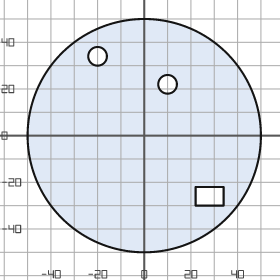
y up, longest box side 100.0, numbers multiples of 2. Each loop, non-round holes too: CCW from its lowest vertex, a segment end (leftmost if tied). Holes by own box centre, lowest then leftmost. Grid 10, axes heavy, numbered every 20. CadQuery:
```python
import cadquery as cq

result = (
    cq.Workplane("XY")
    .moveTo(0.0, 0.0)
    .circle(50.0)
    .moveTo(22.0, -30.0)
    .lineTo(34.0, -30.0)
    .lineTo(34.0, -22.0)
    .lineTo(22.0, -22.0)
    .close()
    .moveTo(10.0, 22.0)
    .circle(4.0)
    .moveTo(-20.0, 34.0)
    .circle(4.0)
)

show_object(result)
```